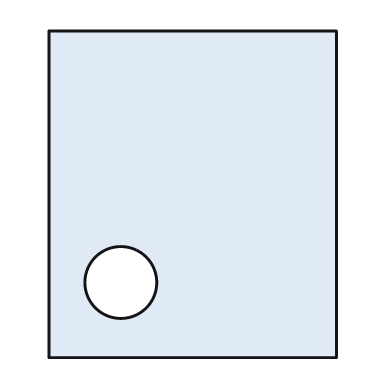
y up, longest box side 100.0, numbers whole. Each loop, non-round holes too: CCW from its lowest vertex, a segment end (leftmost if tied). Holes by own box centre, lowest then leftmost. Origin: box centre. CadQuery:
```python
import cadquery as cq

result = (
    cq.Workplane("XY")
    .moveTo(-44.0, -50.0)
    .lineTo(44.0, -50.0)
    .lineTo(44.0, 50.0)
    .lineTo(-44.0, 50.0)
    .close()
    .moveTo(-22.0, -27.0)
    .circle(11.0)
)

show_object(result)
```